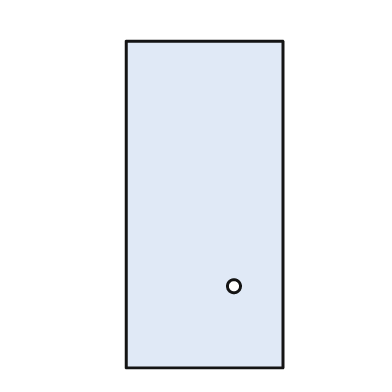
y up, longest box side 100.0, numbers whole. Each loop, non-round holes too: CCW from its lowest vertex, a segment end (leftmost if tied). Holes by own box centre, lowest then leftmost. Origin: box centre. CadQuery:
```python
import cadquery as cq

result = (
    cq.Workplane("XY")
    .moveTo(-24.0, -50.0)
    .lineTo(24.0, -50.0)
    .lineTo(24.0, 50.0)
    .lineTo(-24.0, 50.0)
    .close()
    .moveTo(9.0, -25.0)
    .circle(2.0)
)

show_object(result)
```